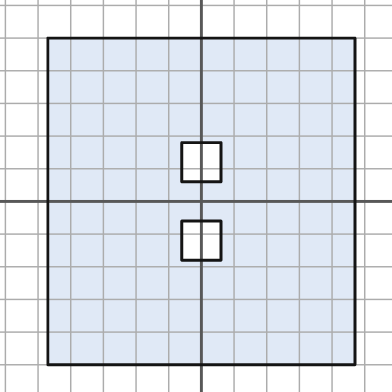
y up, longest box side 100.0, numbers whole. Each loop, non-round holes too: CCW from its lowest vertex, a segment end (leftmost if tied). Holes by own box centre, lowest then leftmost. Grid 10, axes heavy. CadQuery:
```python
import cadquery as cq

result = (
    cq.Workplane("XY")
    .moveTo(-47.0, -50.0)
    .lineTo(47.0, -50.0)
    .lineTo(47.0, 50.0)
    .lineTo(-47.0, 50.0)
    .close()
    .moveTo(-6.0, -18.0)
    .lineTo(6.0, -18.0)
    .lineTo(6.0, -6.0)
    .lineTo(-6.0, -6.0)
    .close()
    .moveTo(-6.0, 6.0)
    .lineTo(6.0, 6.0)
    .lineTo(6.0, 18.0)
    .lineTo(-6.0, 18.0)
    .close()
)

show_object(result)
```